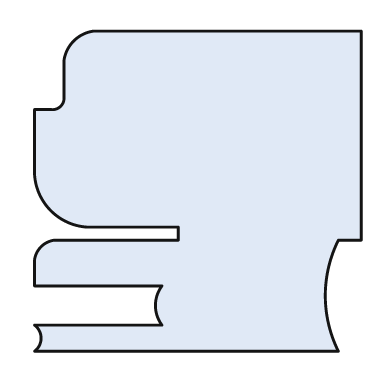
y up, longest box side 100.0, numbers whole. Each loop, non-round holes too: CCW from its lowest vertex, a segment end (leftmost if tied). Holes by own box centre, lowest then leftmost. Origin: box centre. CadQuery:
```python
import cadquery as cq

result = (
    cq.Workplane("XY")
    .moveTo(-50.0, -49.0)
    .lineTo(43.0, -49.0)
    .threePointArc((39.0, -32.0), (43.0, -15.0))
    .lineTo(50.0, -15.0)
    .lineTo(50.0, 49.0)
    .lineTo(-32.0, 49.0)
    .threePointArc((-38.0, 46.0), (-41.0, 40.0))
    .lineTo(-41.0, 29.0)
    .threePointArc((-42.0, 26.0), (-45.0, 25.0))
    .lineTo(-50.0, 25.0)
    .lineTo(-50.0, 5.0)
    .threePointArc((-45.0, -6.0), (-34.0, -11.0))
    .lineTo(-6.0, -11.0)
    .lineTo(-6.0, -15.0)
    .lineTo(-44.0, -15.0)
    .threePointArc((-48.0, -17.0), (-50.0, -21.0))
    .lineTo(-50.0, -29.0)
    .lineTo(-11.0, -29.0)
    .threePointArc((-13.0, -35.0), (-11.0, -41.0))
    .lineTo(-50.0, -41.0)
    .threePointArc((-48.0, -45.0), (-50.0, -49.0))
    .close()
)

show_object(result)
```